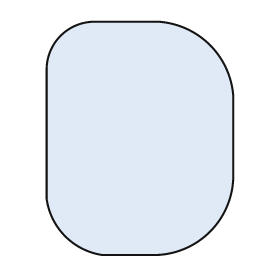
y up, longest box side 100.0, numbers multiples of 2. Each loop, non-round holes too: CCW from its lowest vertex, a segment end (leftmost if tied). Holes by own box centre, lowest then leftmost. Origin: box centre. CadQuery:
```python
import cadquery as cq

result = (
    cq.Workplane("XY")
    .moveTo(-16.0, -50.0)
    .lineTo(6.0, -50.0)
    .threePointArc((30.0, -40.0), (40.0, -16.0))
    .lineTo(40.0, 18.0)
    .threePointArc((30.0, 40.0), (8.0, 50.0))
    .lineTo(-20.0, 50.0)
    .threePointArc((-34.0, 44.0), (-40.0, 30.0))
    .lineTo(-40.0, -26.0)
    .threePointArc((-32.0, -42.0), (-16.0, -50.0))
    .close()
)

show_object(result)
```